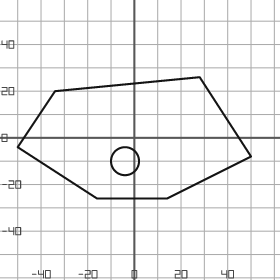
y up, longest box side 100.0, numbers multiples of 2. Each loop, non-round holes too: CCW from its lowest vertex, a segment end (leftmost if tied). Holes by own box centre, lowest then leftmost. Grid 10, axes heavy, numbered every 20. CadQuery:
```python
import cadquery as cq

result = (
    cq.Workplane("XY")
    .moveTo(-16.0, -26.0)
    .lineTo(14.0, -26.0)
    .lineTo(50.0, -8.0)
    .lineTo(28.0, 26.0)
    .lineTo(-34.0, 20.0)
    .lineTo(-50.0, -4.0)
    .close()
    .moveTo(-4.0, -10.0)
    .circle(6.0)
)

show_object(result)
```